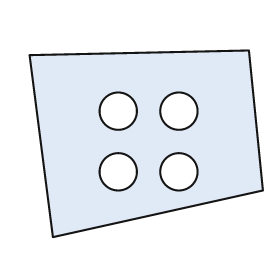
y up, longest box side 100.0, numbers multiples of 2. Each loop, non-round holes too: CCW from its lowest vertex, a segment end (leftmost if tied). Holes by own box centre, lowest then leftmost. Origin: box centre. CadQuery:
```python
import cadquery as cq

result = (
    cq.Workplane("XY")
    .moveTo(-40.0, -40.0)
    .lineTo(50.0, -20.0)
    .lineTo(44.0, 40.0)
    .lineTo(-50.0, 38.0)
    .close()
    .moveTo(-12.0, -12.0)
    .circle(8.0)
    .moveTo(14.0, -12.0)
    .circle(8.0)
    .moveTo(-12.0, 14.0)
    .circle(8.0)
    .moveTo(14.0, 14.0)
    .circle(8.0)
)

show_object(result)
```